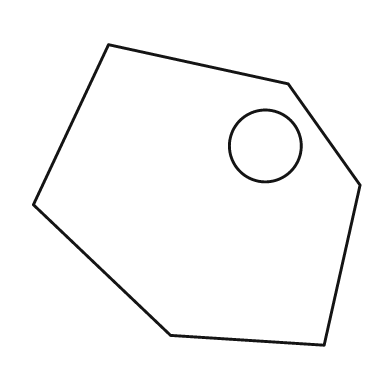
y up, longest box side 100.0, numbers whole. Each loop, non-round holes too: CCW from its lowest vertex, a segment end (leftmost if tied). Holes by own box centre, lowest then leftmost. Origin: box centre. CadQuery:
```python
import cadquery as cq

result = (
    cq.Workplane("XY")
    .moveTo(39.0, -46.0)
    .lineTo(50.0, 3.0)
    .lineTo(28.0, 34.0)
    .lineTo(-27.0, 46.0)
    .lineTo(-50.0, -3.0)
    .lineTo(-8.0, -43.0)
    .close()
    .moveTo(21.0, 15.0)
    .circle(11.0)
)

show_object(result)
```